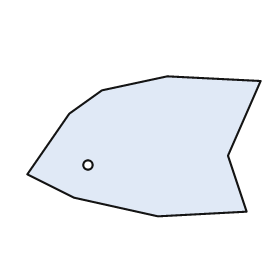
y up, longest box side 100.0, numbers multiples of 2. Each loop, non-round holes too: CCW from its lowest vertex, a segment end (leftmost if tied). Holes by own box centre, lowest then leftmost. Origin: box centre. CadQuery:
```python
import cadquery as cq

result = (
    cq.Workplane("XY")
    .moveTo(6.0, -30.0)
    .lineTo(44.0, -28.0)
    .lineTo(36.0, -4.0)
    .lineTo(50.0, 28.0)
    .lineTo(10.0, 30.0)
    .lineTo(-18.0, 24.0)
    .lineTo(-32.0, 14.0)
    .lineTo(-50.0, -12.0)
    .lineTo(-30.0, -22.0)
    .close()
    .moveTo(-24.0, -8.0)
    .circle(2.0)
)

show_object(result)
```